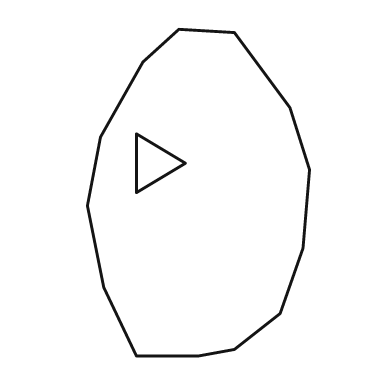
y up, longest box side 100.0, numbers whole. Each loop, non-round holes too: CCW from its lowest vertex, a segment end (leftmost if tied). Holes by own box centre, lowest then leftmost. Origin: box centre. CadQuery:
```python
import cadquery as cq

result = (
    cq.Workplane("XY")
    .moveTo(-19.0, -50.0)
    .lineTo(0.0, -50.0)
    .lineTo(11.0, -48.0)
    .lineTo(25.0, -37.0)
    .lineTo(32.0, -17.0)
    .lineTo(34.0, 7.0)
    .lineTo(28.0, 26.0)
    .lineTo(11.0, 49.0)
    .lineTo(-6.0, 50.0)
    .lineTo(-17.0, 40.0)
    .lineTo(-30.0, 17.0)
    .lineTo(-34.0, -4.0)
    .lineTo(-29.0, -29.0)
    .close()
    .moveTo(-19.0, 0.0)
    .lineTo(-4.0, 9.0)
    .lineTo(-19.0, 18.0)
    .close()
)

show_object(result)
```